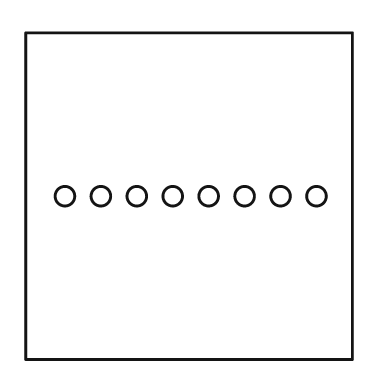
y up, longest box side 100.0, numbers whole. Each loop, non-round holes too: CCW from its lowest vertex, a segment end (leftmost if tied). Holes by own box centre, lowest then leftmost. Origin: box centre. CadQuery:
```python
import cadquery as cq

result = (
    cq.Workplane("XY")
    .moveTo(-50.0, -50.0)
    .lineTo(50.0, -50.0)
    .lineTo(50.0, 50.0)
    .lineTo(-50.0, 50.0)
    .close()
    .moveTo(-38.0, 0.0)
    .circle(3.0)
    .moveTo(-27.0, 0.0)
    .circle(3.0)
    .moveTo(-16.0, 0.0)
    .circle(3.0)
    .moveTo(-5.0, 0.0)
    .circle(3.0)
    .moveTo(6.0, 0.0)
    .circle(3.0)
    .moveTo(17.0, 0.0)
    .circle(3.0)
    .moveTo(28.0, 0.0)
    .circle(3.0)
    .moveTo(39.0, 0.0)
    .circle(3.0)
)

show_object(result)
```